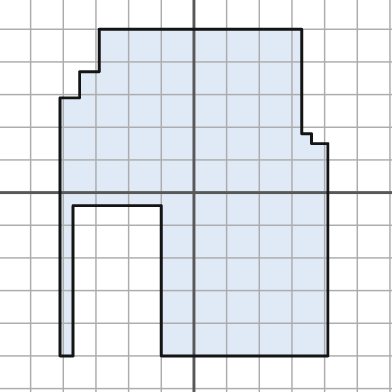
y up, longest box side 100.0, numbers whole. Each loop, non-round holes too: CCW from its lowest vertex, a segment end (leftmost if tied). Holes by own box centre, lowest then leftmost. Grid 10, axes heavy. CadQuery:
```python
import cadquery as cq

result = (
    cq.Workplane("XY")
    .moveTo(-41.0, -50.0)
    .lineTo(-37.0, -50.0)
    .lineTo(-37.0, -4.0)
    .lineTo(-10.0, -4.0)
    .lineTo(-10.0, -50.0)
    .lineTo(41.0, -50.0)
    .lineTo(41.0, 15.0)
    .lineTo(36.0, 15.0)
    .lineTo(36.0, 18.0)
    .lineTo(33.0, 18.0)
    .lineTo(33.0, 50.0)
    .lineTo(-29.0, 50.0)
    .lineTo(-29.0, 37.0)
    .lineTo(-35.0, 37.0)
    .lineTo(-35.0, 29.0)
    .lineTo(-41.0, 29.0)
    .close()
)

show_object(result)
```